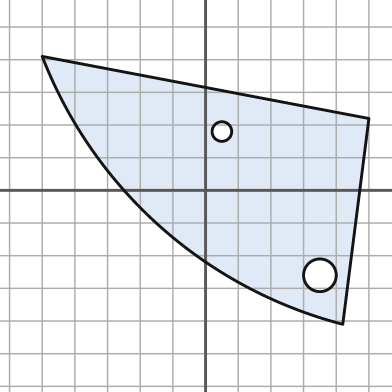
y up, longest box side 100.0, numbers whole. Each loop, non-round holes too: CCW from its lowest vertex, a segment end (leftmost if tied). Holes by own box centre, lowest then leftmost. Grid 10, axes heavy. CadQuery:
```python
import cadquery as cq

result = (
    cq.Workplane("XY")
    .moveTo(42.0, -41.0)
    .lineTo(50.0, 22.0)
    .lineTo(-50.0, 41.0)
    .threePointArc((-14.0, -11.0), (42.0, -41.0))
    .close()
    .moveTo(35.0, -26.0)
    .circle(5.0)
    .moveTo(5.0, 18.0)
    .circle(3.0)
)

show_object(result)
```